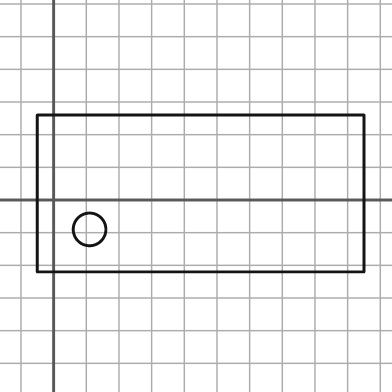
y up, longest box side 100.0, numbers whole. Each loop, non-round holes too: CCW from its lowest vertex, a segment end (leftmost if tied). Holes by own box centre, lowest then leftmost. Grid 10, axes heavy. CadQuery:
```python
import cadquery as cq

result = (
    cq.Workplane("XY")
    .moveTo(-5.0, -22.0)
    .lineTo(95.0, -22.0)
    .lineTo(95.0, 26.0)
    .lineTo(-5.0, 26.0)
    .close()
    .moveTo(11.0, -9.0)
    .circle(5.0)
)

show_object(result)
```